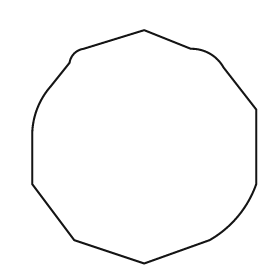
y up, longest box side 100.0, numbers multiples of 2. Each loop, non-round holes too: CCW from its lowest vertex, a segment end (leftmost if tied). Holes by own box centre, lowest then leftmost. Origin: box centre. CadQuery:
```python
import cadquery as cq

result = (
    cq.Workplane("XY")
    .moveTo(0.0, -50.0)
    .lineTo(28.0, -40.0)
    .threePointArc((40.0, -30.0), (48.0, -16.0))
    .lineTo(48.0, 16.0)
    .lineTo(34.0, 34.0)
    .threePointArc((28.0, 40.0), (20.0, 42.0))
    .lineTo(0.0, 50.0)
    .lineTo(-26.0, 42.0)
    .threePointArc((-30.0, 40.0), (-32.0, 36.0))
    .lineTo(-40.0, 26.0)
    .threePointArc((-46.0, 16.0), (-48.0, 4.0))
    .lineTo(-48.0, -16.0)
    .lineTo(-30.0, -40.0)
    .close()
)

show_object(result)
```